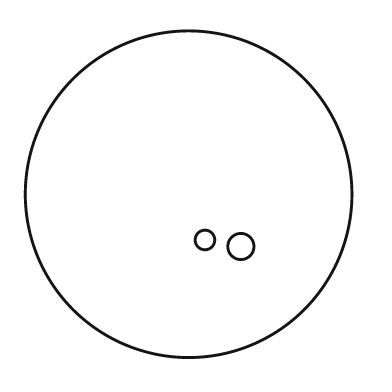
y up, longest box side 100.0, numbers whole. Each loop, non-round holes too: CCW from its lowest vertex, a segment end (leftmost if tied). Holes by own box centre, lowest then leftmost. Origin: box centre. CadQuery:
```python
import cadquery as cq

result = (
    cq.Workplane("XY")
    .moveTo(0.0, 0.0)
    .circle(50.0)
    .moveTo(16.0, -16.0)
    .circle(4.0)
    .moveTo(5.0, -14.0)
    .circle(3.0)
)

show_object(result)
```